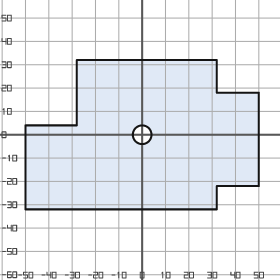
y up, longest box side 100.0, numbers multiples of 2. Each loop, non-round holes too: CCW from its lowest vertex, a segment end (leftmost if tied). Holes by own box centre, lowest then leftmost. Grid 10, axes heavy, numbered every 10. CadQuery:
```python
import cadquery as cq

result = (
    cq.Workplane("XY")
    .moveTo(-50.0, -32.0)
    .lineTo(32.0, -32.0)
    .lineTo(32.0, -22.0)
    .lineTo(50.0, -22.0)
    .lineTo(50.0, 18.0)
    .lineTo(32.0, 18.0)
    .lineTo(32.0, 32.0)
    .lineTo(-28.0, 32.0)
    .lineTo(-28.0, 4.0)
    .lineTo(-50.0, 4.0)
    .close()
    .moveTo(0.0, 0.0)
    .circle(4.0)
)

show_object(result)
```